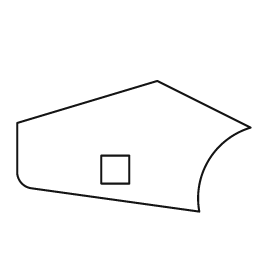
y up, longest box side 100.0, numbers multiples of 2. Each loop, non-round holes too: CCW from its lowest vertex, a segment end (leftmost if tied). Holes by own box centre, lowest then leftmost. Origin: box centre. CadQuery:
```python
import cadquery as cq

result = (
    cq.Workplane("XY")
    .moveTo(28.0, -28.0)
    .threePointArc((32.0, -6.0), (50.0, 8.0))
    .lineTo(10.0, 28.0)
    .lineTo(-50.0, 10.0)
    .lineTo(-50.0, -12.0)
    .threePointArc((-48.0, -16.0), (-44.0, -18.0))
    .close()
    .moveTo(-14.0, -16.0)
    .lineTo(-2.0, -16.0)
    .lineTo(-2.0, -4.0)
    .lineTo(-14.0, -4.0)
    .close()
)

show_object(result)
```